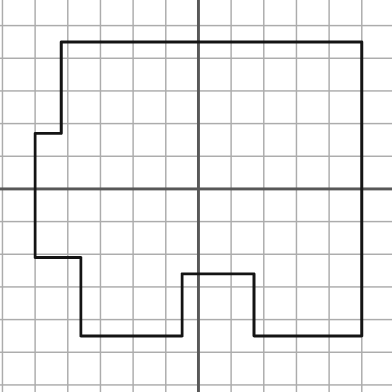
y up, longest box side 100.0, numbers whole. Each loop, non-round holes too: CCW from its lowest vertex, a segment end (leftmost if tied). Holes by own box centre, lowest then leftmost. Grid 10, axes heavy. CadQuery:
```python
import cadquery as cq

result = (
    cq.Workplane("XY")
    .moveTo(-36.0, -45.0)
    .lineTo(-5.0, -45.0)
    .lineTo(-5.0, -26.0)
    .lineTo(17.0, -26.0)
    .lineTo(17.0, -45.0)
    .lineTo(50.0, -45.0)
    .lineTo(50.0, 45.0)
    .lineTo(-42.0, 45.0)
    .lineTo(-42.0, 17.0)
    .lineTo(-50.0, 17.0)
    .lineTo(-50.0, -21.0)
    .lineTo(-36.0, -21.0)
    .close()
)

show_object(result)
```